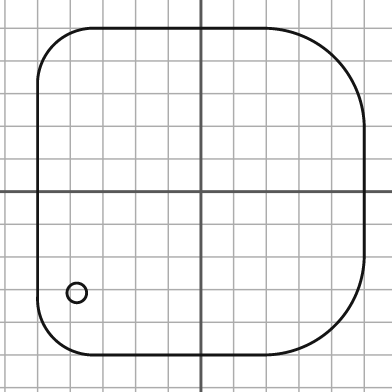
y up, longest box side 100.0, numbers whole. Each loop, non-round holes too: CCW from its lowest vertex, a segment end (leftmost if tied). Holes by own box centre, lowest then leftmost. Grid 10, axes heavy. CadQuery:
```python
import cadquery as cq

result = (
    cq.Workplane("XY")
    .moveTo(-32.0, -50.0)
    .lineTo(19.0, -50.0)
    .threePointArc((41.0, -41.0), (50.0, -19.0))
    .lineTo(50.0, 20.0)
    .threePointArc((41.0, 41.0), (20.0, 50.0))
    .lineTo(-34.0, 50.0)
    .threePointArc((-45.0, 45.0), (-50.0, 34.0))
    .lineTo(-50.0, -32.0)
    .threePointArc((-45.0, -45.0), (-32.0, -50.0))
    .close()
    .moveTo(-38.0, -31.0)
    .circle(3.0)
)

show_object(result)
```